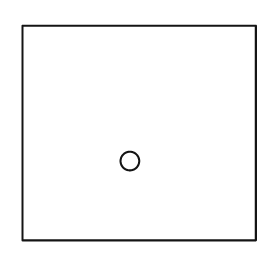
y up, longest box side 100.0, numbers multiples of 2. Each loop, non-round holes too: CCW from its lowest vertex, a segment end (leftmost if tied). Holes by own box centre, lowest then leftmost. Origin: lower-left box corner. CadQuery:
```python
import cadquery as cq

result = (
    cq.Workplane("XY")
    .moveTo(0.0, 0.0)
    .lineTo(100.0, 0.0)
    .lineTo(100.0, 92.0)
    .lineTo(0.0, 92.0)
    .close()
    .moveTo(46.0, 34.0)
    .circle(4.0)
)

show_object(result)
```